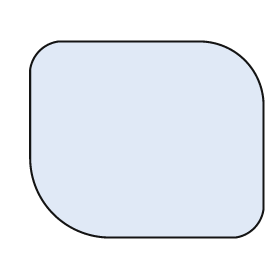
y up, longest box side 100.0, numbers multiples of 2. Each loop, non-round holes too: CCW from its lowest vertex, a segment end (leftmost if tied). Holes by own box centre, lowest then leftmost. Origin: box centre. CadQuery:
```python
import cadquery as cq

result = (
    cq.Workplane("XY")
    .moveTo(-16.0, -42.0)
    .lineTo(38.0, -42.0)
    .threePointArc((46.0, -38.0), (50.0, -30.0))
    .lineTo(50.0, 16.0)
    .threePointArc((42.0, 34.0), (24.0, 42.0))
    .lineTo(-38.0, 42.0)
    .threePointArc((-46.0, 38.0), (-50.0, 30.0))
    .lineTo(-50.0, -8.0)
    .threePointArc((-40.0, -32.0), (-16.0, -42.0))
    .close()
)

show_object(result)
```